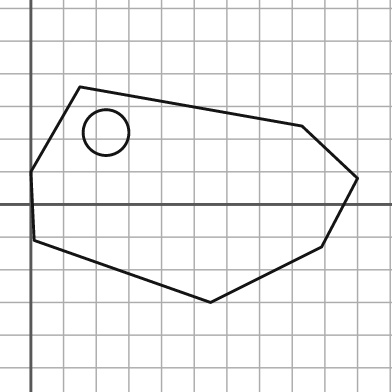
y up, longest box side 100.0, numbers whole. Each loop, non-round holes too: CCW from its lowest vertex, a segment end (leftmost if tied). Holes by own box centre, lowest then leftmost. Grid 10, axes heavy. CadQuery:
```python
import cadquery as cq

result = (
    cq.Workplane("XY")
    .moveTo(55.0, -30.0)
    .lineTo(89.0, -13.0)
    .lineTo(100.0, 8.0)
    .lineTo(83.0, 24.0)
    .lineTo(15.0, 36.0)
    .lineTo(0.0, 10.0)
    .lineTo(1.0, -11.0)
    .close()
    .moveTo(23.0, 22.0)
    .circle(7.0)
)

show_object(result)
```